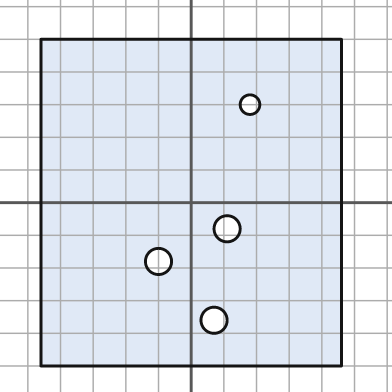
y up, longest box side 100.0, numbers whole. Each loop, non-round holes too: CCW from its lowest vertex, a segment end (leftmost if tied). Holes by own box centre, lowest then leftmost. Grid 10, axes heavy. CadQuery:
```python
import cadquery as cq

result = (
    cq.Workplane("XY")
    .moveTo(-46.0, -50.0)
    .lineTo(46.0, -50.0)
    .lineTo(46.0, 50.0)
    .lineTo(-46.0, 50.0)
    .close()
    .moveTo(7.0, -36.0)
    .circle(4.0)
    .moveTo(-10.0, -18.0)
    .circle(4.0)
    .moveTo(11.0, -8.0)
    .circle(4.0)
    .moveTo(18.0, 30.0)
    .circle(3.0)
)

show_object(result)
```